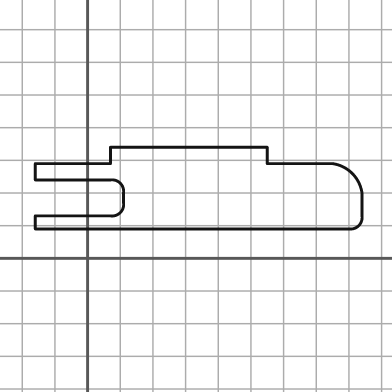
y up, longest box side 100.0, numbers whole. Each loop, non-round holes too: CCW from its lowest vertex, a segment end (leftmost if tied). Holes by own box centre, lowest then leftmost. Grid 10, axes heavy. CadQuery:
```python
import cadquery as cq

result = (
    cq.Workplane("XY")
    .moveTo(-16.0, 9.0)
    .lineTo(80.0, 9.0)
    .threePointArc((83.0, 10.0), (84.0, 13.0))
    .lineTo(84.0, 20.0)
    .threePointArc((81.0, 26.0), (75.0, 29.0))
    .lineTo(55.0, 29.0)
    .lineTo(55.0, 34.0)
    .lineTo(7.0, 34.0)
    .lineTo(7.0, 29.0)
    .lineTo(-16.0, 29.0)
    .lineTo(-16.0, 24.0)
    .lineTo(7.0, 24.0)
    .threePointArc((10.0, 23.0), (11.0, 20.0))
    .lineTo(11.0, 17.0)
    .threePointArc((10.0, 14.0), (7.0, 13.0))
    .lineTo(-16.0, 13.0)
    .close()
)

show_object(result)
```